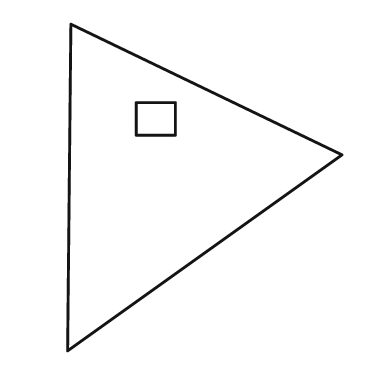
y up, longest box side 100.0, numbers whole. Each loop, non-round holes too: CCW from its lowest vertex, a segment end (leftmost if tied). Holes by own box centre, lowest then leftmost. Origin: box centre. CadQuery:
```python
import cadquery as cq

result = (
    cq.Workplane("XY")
    .moveTo(-42.0, -50.0)
    .lineTo(42.0, 10.0)
    .lineTo(-41.0, 50.0)
    .close()
    .moveTo(-21.0, 16.0)
    .lineTo(-9.0, 16.0)
    .lineTo(-9.0, 26.0)
    .lineTo(-21.0, 26.0)
    .close()
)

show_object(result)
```